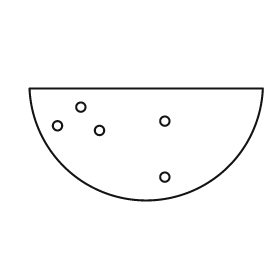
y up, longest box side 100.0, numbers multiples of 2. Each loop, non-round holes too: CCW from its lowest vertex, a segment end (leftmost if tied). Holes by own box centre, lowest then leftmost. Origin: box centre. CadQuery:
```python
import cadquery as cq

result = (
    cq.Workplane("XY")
    .moveTo(-50.0, 24.0)
    .threePointArc((0.0, -24.0), (50.0, 24.0))
    .close()
    .moveTo(8.0, -14.0)
    .circle(2.0)
    .moveTo(-20.0, 6.0)
    .circle(2.0)
    .moveTo(-38.0, 8.0)
    .circle(2.0)
    .moveTo(8.0, 10.0)
    .circle(2.0)
    .moveTo(-28.0, 16.0)
    .circle(2.0)
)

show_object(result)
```